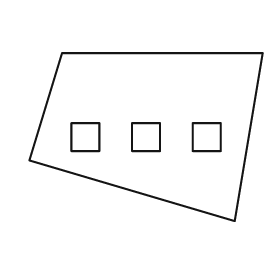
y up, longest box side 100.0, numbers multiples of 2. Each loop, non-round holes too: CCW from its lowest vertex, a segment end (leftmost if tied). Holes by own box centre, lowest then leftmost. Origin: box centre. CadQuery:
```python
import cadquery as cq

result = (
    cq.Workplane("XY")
    .moveTo(38.0, -36.0)
    .lineTo(50.0, 36.0)
    .lineTo(-36.0, 36.0)
    .lineTo(-50.0, -10.0)
    .close()
    .moveTo(-32.0, -6.0)
    .lineTo(-20.0, -6.0)
    .lineTo(-20.0, 6.0)
    .lineTo(-32.0, 6.0)
    .close()
    .moveTo(-6.0, -6.0)
    .lineTo(6.0, -6.0)
    .lineTo(6.0, 6.0)
    .lineTo(-6.0, 6.0)
    .close()
    .moveTo(20.0, -6.0)
    .lineTo(32.0, -6.0)
    .lineTo(32.0, 6.0)
    .lineTo(20.0, 6.0)
    .close()
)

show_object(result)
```